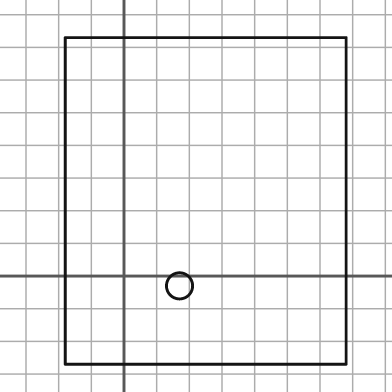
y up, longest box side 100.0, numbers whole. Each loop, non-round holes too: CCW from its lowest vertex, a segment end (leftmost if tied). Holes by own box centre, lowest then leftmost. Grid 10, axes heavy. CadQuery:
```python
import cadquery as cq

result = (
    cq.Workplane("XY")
    .moveTo(-18.0, -27.0)
    .lineTo(68.0, -27.0)
    .lineTo(68.0, 73.0)
    .lineTo(-18.0, 73.0)
    .close()
    .moveTo(17.0, -3.0)
    .circle(4.0)
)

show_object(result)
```